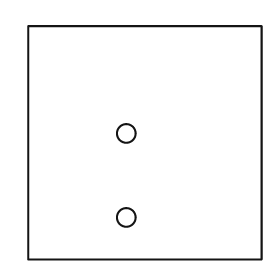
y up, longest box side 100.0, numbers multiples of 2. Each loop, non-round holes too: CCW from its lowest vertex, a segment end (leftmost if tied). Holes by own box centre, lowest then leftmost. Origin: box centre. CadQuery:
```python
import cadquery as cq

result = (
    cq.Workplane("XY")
    .moveTo(-50.0, -50.0)
    .lineTo(50.0, -50.0)
    .lineTo(50.0, 50.0)
    .lineTo(-50.0, 50.0)
    .close()
    .moveTo(-8.0, -32.0)
    .circle(4.0)
    .moveTo(-8.0, 4.0)
    .circle(4.0)
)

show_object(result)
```